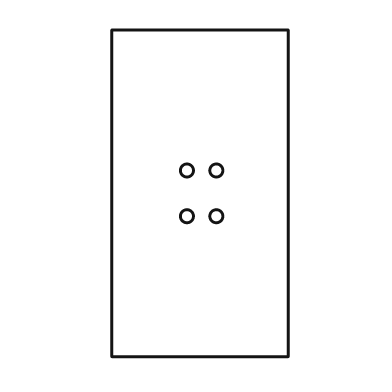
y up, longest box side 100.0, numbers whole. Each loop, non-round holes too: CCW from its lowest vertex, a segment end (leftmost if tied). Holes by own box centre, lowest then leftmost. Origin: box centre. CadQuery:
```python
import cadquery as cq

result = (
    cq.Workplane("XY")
    .moveTo(-27.0, -50.0)
    .lineTo(27.0, -50.0)
    .lineTo(27.0, 50.0)
    .lineTo(-27.0, 50.0)
    .close()
    .moveTo(-4.0, -7.0)
    .circle(2.0)
    .moveTo(5.0, -7.0)
    .circle(2.0)
    .moveTo(-4.0, 7.0)
    .circle(2.0)
    .moveTo(5.0, 7.0)
    .circle(2.0)
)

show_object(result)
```